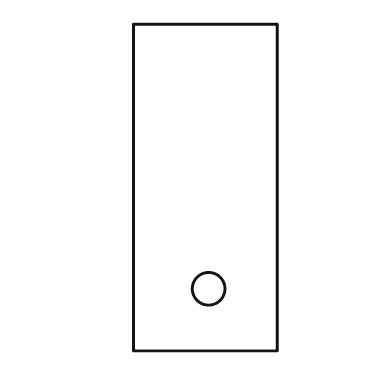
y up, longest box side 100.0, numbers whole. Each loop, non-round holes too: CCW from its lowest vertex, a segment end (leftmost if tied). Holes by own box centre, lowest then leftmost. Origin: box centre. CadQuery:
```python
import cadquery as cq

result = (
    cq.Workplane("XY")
    .moveTo(-22.0, -50.0)
    .lineTo(22.0, -50.0)
    .lineTo(22.0, 50.0)
    .lineTo(-22.0, 50.0)
    .close()
    .moveTo(1.0, -31.0)
    .circle(5.0)
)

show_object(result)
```